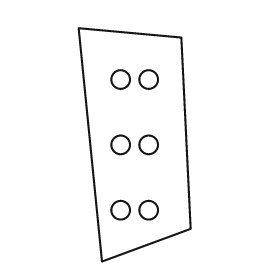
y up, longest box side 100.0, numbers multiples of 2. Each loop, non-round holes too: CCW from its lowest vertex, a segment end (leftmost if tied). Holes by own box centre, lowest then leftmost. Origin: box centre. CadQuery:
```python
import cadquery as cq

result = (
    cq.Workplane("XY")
    .moveTo(-14.0, -50.0)
    .lineTo(24.0, -36.0)
    .lineTo(20.0, 46.0)
    .lineTo(-24.0, 50.0)
    .close()
    .moveTo(-6.0, -28.0)
    .circle(4.0)
    .moveTo(6.0, -28.0)
    .circle(4.0)
    .moveTo(-6.0, 0.0)
    .circle(4.0)
    .moveTo(6.0, 0.0)
    .circle(4.0)
    .moveTo(-6.0, 28.0)
    .circle(4.0)
    .moveTo(6.0, 28.0)
    .circle(4.0)
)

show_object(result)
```